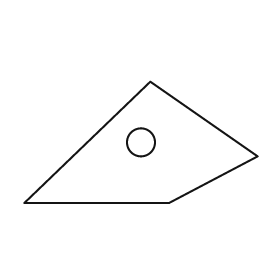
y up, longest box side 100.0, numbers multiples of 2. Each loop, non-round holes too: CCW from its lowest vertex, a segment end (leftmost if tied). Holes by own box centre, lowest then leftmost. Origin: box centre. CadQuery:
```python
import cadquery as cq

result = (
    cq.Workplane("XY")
    .moveTo(-50.0, -26.0)
    .lineTo(12.0, -26.0)
    .lineTo(50.0, -6.0)
    .lineTo(4.0, 26.0)
    .close()
    .moveTo(0.0, 0.0)
    .circle(6.0)
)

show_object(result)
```